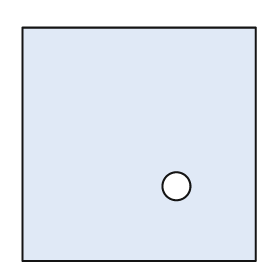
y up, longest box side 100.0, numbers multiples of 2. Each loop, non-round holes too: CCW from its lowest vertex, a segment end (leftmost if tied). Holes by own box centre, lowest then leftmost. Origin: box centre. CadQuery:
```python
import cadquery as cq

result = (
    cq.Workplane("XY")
    .moveTo(-50.0, -50.0)
    .lineTo(50.0, -50.0)
    .lineTo(50.0, 50.0)
    .lineTo(-50.0, 50.0)
    .close()
    .moveTo(16.0, -18.0)
    .circle(6.0)
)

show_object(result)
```